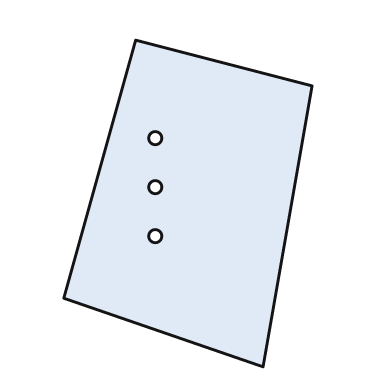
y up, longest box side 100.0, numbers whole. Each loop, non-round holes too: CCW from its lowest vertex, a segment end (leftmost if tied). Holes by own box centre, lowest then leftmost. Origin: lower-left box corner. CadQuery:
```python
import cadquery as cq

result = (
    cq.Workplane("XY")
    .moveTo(61.0, 0.0)
    .lineTo(76.0, 86.0)
    .lineTo(22.0, 100.0)
    .lineTo(0.0, 21.0)
    .close()
    .moveTo(28.0, 40.0)
    .circle(2.0)
    .moveTo(28.0, 55.0)
    .circle(2.0)
    .moveTo(28.0, 70.0)
    .circle(2.0)
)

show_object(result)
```